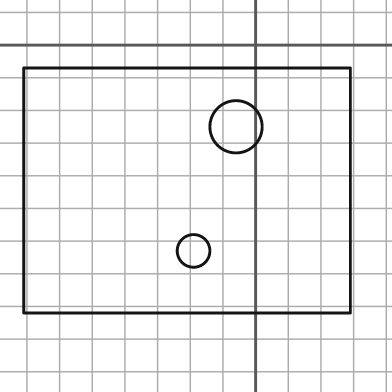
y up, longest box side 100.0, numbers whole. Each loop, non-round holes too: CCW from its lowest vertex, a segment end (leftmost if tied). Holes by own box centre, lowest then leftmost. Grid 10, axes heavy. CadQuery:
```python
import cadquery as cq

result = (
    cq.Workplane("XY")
    .moveTo(-71.0, -82.0)
    .lineTo(29.0, -82.0)
    .lineTo(29.0, -7.0)
    .lineTo(-71.0, -7.0)
    .close()
    .moveTo(-19.0, -63.0)
    .circle(5.0)
    .moveTo(-6.0, -25.0)
    .circle(8.0)
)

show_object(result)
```